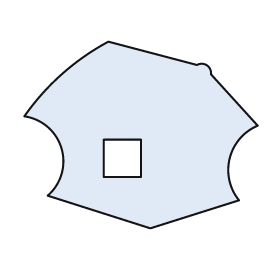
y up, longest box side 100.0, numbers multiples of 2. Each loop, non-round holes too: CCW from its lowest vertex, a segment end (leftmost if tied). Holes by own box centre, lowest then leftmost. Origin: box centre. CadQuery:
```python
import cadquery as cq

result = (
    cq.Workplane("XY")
    .moveTo(4.0, -40.0)
    .lineTo(42.0, -28.0)
    .threePointArc((38.0, -10.0), (50.0, 4.0))
    .lineTo(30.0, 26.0)
    .threePointArc((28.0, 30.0), (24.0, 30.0))
    .lineTo(-14.0, 40.0)
    .threePointArc((-34.0, 26.0), (-50.0, 8.0))
    .threePointArc((-34.0, -6.0), (-40.0, -26.0))
    .close()
    .moveTo(-16.0, -18.0)
    .lineTo(0.0, -18.0)
    .lineTo(0.0, -2.0)
    .lineTo(-16.0, -2.0)
    .close()
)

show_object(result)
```